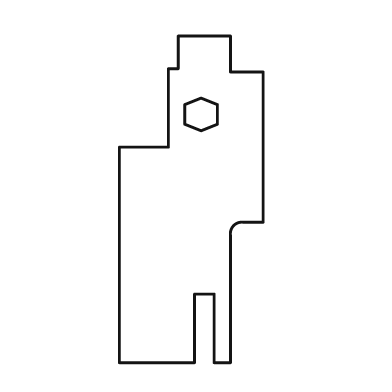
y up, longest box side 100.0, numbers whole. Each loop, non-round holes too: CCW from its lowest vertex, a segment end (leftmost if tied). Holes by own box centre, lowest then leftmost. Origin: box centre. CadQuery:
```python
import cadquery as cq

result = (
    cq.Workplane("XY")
    .moveTo(-22.0, -50.0)
    .lineTo(1.0, -50.0)
    .lineTo(1.0, -29.0)
    .lineTo(7.0, -29.0)
    .lineTo(7.0, -50.0)
    .lineTo(12.0, -50.0)
    .lineTo(12.0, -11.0)
    .threePointArc((13.0, -8.0), (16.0, -7.0))
    .lineTo(22.0, -7.0)
    .lineTo(22.0, 39.0)
    .lineTo(12.0, 39.0)
    .lineTo(12.0, 50.0)
    .lineTo(-4.0, 50.0)
    .lineTo(-4.0, 40.0)
    .lineTo(-7.0, 40.0)
    .lineTo(-7.0, 16.0)
    .lineTo(-22.0, 16.0)
    .close()
    .moveTo(3.0, 21.0)
    .lineTo(8.0, 23.0)
    .lineTo(8.0, 29.0)
    .lineTo(3.0, 31.0)
    .lineTo(-2.0, 29.0)
    .lineTo(-2.0, 23.0)
    .close()
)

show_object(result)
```